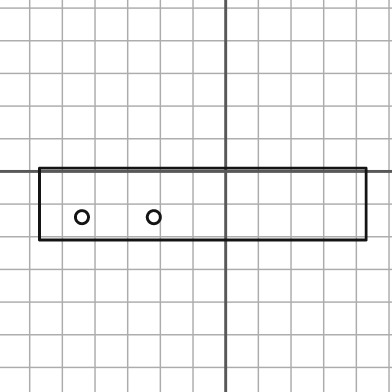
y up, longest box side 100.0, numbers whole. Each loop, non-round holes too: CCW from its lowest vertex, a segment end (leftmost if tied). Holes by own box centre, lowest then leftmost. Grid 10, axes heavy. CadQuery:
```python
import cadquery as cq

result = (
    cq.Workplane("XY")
    .moveTo(-57.0, -21.0)
    .lineTo(43.0, -21.0)
    .lineTo(43.0, 1.0)
    .lineTo(-57.0, 1.0)
    .close()
    .moveTo(-44.0, -14.0)
    .circle(2.0)
    .moveTo(-22.0, -14.0)
    .circle(2.0)
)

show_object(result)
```